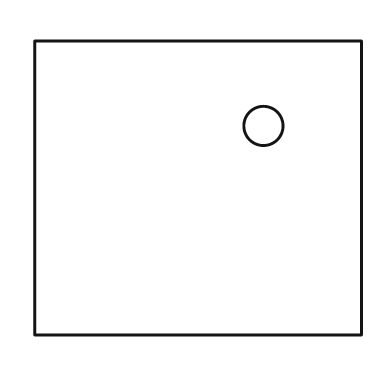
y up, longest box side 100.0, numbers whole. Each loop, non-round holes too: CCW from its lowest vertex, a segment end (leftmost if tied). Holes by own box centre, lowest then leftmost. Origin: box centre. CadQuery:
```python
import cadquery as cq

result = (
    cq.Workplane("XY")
    .moveTo(-50.0, -45.0)
    .lineTo(50.0, -45.0)
    .lineTo(50.0, 45.0)
    .lineTo(-50.0, 45.0)
    .close()
    .moveTo(20.0, 19.0)
    .circle(6.0)
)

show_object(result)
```